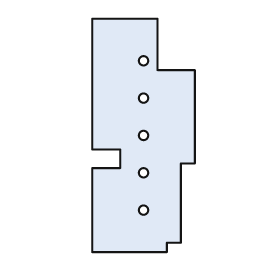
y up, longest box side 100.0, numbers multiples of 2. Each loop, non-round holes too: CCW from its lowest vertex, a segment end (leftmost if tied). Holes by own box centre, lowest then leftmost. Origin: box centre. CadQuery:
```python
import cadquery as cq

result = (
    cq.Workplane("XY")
    .moveTo(-22.0, -50.0)
    .lineTo(10.0, -50.0)
    .lineTo(10.0, -46.0)
    .lineTo(16.0, -46.0)
    .lineTo(16.0, -12.0)
    .lineTo(22.0, -12.0)
    .lineTo(22.0, 28.0)
    .lineTo(6.0, 28.0)
    .lineTo(6.0, 50.0)
    .lineTo(-22.0, 50.0)
    .lineTo(-22.0, -6.0)
    .lineTo(-10.0, -6.0)
    .lineTo(-10.0, -14.0)
    .lineTo(-22.0, -14.0)
    .close()
    .moveTo(0.0, -32.0)
    .circle(2.0)
    .moveTo(0.0, -16.0)
    .circle(2.0)
    .moveTo(0.0, 0.0)
    .circle(2.0)
    .moveTo(0.0, 16.0)
    .circle(2.0)
    .moveTo(0.0, 32.0)
    .circle(2.0)
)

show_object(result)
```